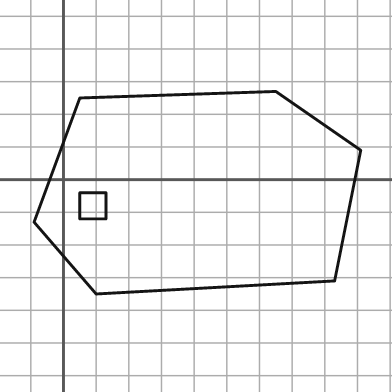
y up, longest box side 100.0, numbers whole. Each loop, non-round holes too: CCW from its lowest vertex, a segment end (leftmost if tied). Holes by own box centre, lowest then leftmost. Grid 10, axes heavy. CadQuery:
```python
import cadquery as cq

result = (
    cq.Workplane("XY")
    .moveTo(10.0, -35.0)
    .lineTo(83.0, -31.0)
    .lineTo(91.0, 9.0)
    .lineTo(65.0, 27.0)
    .lineTo(5.0, 25.0)
    .lineTo(-9.0, -13.0)
    .close()
    .moveTo(5.0, -12.0)
    .lineTo(13.0, -12.0)
    .lineTo(13.0, -4.0)
    .lineTo(5.0, -4.0)
    .close()
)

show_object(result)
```